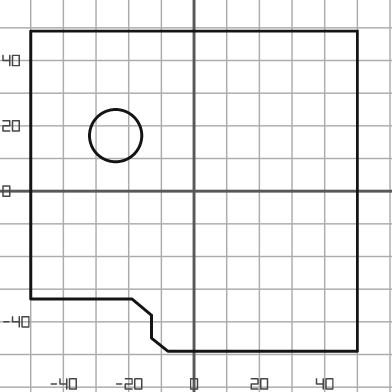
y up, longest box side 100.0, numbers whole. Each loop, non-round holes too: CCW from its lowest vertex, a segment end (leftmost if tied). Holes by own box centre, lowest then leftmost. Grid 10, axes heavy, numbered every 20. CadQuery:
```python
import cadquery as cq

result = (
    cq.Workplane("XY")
    .moveTo(-8.0, -49.0)
    .lineTo(50.0, -49.0)
    .lineTo(50.0, 49.0)
    .lineTo(-50.0, 49.0)
    .lineTo(-50.0, -33.0)
    .lineTo(-19.0, -33.0)
    .lineTo(-13.0, -38.0)
    .lineTo(-13.0, -45.0)
    .close()
    .moveTo(-24.0, 17.0)
    .circle(8.0)
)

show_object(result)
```